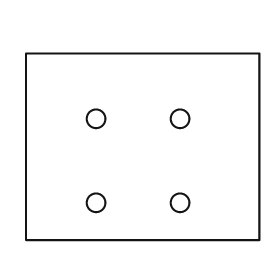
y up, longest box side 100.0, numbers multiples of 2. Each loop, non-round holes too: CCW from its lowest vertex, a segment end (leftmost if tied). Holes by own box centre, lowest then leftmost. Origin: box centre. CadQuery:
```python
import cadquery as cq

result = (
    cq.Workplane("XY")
    .moveTo(-50.0, -40.0)
    .lineTo(50.0, -40.0)
    .lineTo(50.0, 40.0)
    .lineTo(-50.0, 40.0)
    .close()
    .moveTo(-20.0, -24.0)
    .circle(4.0)
    .moveTo(16.0, -24.0)
    .circle(4.0)
    .moveTo(-20.0, 12.0)
    .circle(4.0)
    .moveTo(16.0, 12.0)
    .circle(4.0)
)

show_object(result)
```